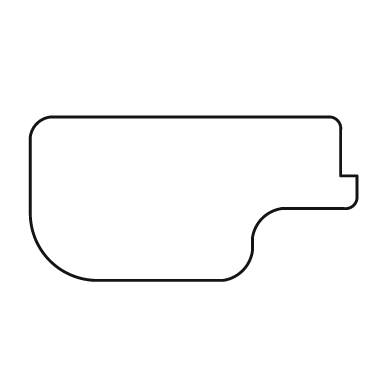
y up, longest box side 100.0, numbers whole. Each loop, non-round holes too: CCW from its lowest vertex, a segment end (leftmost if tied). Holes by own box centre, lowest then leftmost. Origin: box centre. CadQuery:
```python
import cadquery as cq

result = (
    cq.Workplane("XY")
    .moveTo(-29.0, -25.0)
    .lineTo(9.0, -25.0)
    .threePointArc((15.0, -22.0), (18.0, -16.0))
    .lineTo(18.0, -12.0)
    .threePointArc((21.0, -6.0), (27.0, -3.0))
    .lineTo(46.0, -3.0)
    .threePointArc((49.0, -2.0), (50.0, 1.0))
    .lineTo(50.0, 7.0)
    .lineTo(45.0, 7.0)
    .lineTo(45.0, 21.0)
    .threePointArc((44.0, 24.0), (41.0, 25.0))
    .lineTo(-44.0, 25.0)
    .threePointArc((-48.0, 23.0), (-50.0, 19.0))
    .lineTo(-50.0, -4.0)
    .threePointArc((-44.0, -19.0), (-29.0, -25.0))
    .close()
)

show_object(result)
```